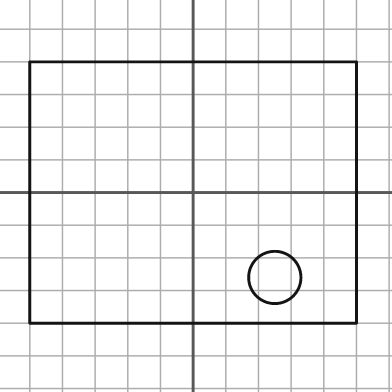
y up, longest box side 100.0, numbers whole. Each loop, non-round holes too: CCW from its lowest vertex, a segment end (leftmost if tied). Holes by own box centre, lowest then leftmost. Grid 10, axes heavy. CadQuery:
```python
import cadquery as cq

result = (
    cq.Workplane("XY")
    .moveTo(-50.0, -40.0)
    .lineTo(50.0, -40.0)
    .lineTo(50.0, 40.0)
    .lineTo(-50.0, 40.0)
    .close()
    .moveTo(25.0, -26.0)
    .circle(8.0)
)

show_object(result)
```